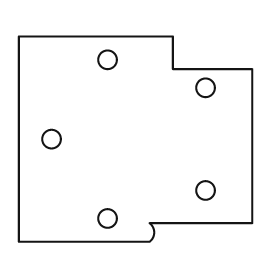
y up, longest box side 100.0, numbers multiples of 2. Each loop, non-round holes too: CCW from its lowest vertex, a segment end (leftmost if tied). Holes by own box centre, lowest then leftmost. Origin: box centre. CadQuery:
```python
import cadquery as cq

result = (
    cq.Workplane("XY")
    .moveTo(-50.0, -44.0)
    .lineTo(6.0, -44.0)
    .threePointArc((8.0, -40.0), (6.0, -36.0))
    .lineTo(50.0, -36.0)
    .lineTo(50.0, 30.0)
    .lineTo(16.0, 30.0)
    .lineTo(16.0, 44.0)
    .lineTo(-50.0, 44.0)
    .close()
    .moveTo(-12.0, -34.0)
    .circle(4.0)
    .moveTo(30.0, -22.0)
    .circle(4.0)
    .moveTo(-36.0, 0.0)
    .circle(4.0)
    .moveTo(30.0, 22.0)
    .circle(4.0)
    .moveTo(-12.0, 34.0)
    .circle(4.0)
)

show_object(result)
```